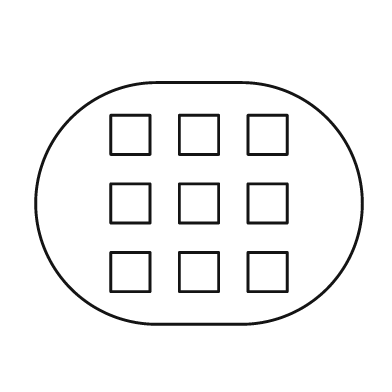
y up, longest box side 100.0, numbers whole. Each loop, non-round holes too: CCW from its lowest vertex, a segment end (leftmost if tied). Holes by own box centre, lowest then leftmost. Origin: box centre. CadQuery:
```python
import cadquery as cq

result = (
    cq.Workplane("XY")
    .moveTo(-13.0, -37.0)
    .lineTo(13.0, -37.0)
    .threePointArc((50.0, 0.0), (13.0, 37.0))
    .lineTo(-13.0, 37.0)
    .threePointArc((-50.0, 0.0), (-13.0, -37.0))
    .close()
    .moveTo(-27.0, -27.0)
    .lineTo(-15.0, -27.0)
    .lineTo(-15.0, -15.0)
    .lineTo(-27.0, -15.0)
    .close()
    .moveTo(-6.0, -27.0)
    .lineTo(6.0, -27.0)
    .lineTo(6.0, -15.0)
    .lineTo(-6.0, -15.0)
    .close()
    .moveTo(15.0, -27.0)
    .lineTo(27.0, -27.0)
    .lineTo(27.0, -15.0)
    .lineTo(15.0, -15.0)
    .close()
    .moveTo(-27.0, -6.0)
    .lineTo(-15.0, -6.0)
    .lineTo(-15.0, 6.0)
    .lineTo(-27.0, 6.0)
    .close()
    .moveTo(-6.0, -6.0)
    .lineTo(6.0, -6.0)
    .lineTo(6.0, 6.0)
    .lineTo(-6.0, 6.0)
    .close()
    .moveTo(15.0, -6.0)
    .lineTo(27.0, -6.0)
    .lineTo(27.0, 6.0)
    .lineTo(15.0, 6.0)
    .close()
    .moveTo(-27.0, 15.0)
    .lineTo(-15.0, 15.0)
    .lineTo(-15.0, 27.0)
    .lineTo(-27.0, 27.0)
    .close()
    .moveTo(-6.0, 15.0)
    .lineTo(6.0, 15.0)
    .lineTo(6.0, 27.0)
    .lineTo(-6.0, 27.0)
    .close()
    .moveTo(15.0, 15.0)
    .lineTo(27.0, 15.0)
    .lineTo(27.0, 27.0)
    .lineTo(15.0, 27.0)
    .close()
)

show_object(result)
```